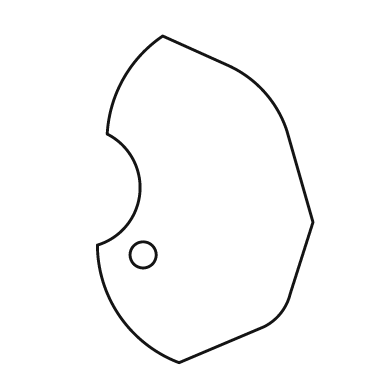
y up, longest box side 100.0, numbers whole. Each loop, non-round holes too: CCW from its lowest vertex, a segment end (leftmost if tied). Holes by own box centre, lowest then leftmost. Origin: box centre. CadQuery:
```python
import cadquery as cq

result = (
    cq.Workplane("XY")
    .moveTo(-8.0, -50.0)
    .lineTo(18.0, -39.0)
    .threePointArc((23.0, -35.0), (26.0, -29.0))
    .lineTo(33.0, -7.0)
    .lineTo(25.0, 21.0)
    .threePointArc((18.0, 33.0), (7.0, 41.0))
    .lineTo(-13.0, 50.0)
    .threePointArc((-25.0, 37.0), (-30.0, 20.0))
    .threePointArc((-20.0, 2.0), (-33.0, -14.0))
    .threePointArc((-26.0, -36.0), (-8.0, -50.0))
    .close()
    .moveTo(-19.0, -17.0)
    .circle(4.0)
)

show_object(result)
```